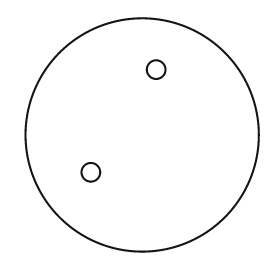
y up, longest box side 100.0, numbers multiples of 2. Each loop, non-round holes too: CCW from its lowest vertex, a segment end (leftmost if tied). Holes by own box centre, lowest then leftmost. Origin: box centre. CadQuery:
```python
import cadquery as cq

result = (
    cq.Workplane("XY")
    .moveTo(0.0, 0.0)
    .circle(50.0)
    .moveTo(-22.0, -16.0)
    .circle(4.0)
    .moveTo(6.0, 28.0)
    .circle(4.0)
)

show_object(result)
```